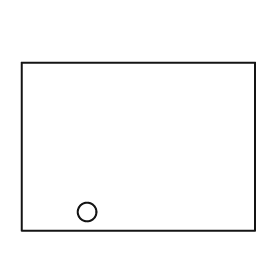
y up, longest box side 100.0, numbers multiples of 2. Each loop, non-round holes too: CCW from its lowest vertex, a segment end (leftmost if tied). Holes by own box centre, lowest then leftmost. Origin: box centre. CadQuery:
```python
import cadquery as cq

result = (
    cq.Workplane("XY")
    .moveTo(-50.0, -36.0)
    .lineTo(50.0, -36.0)
    .lineTo(50.0, 36.0)
    .lineTo(-50.0, 36.0)
    .close()
    .moveTo(-22.0, -28.0)
    .circle(4.0)
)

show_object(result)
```